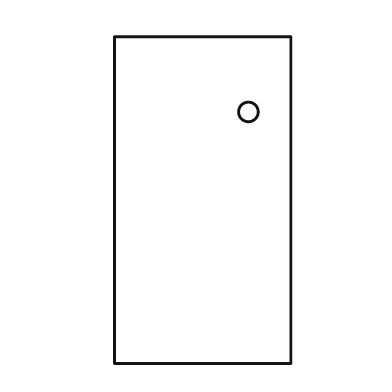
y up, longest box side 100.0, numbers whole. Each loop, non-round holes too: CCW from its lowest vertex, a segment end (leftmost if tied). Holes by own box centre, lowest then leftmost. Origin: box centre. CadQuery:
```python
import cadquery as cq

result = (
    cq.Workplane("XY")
    .moveTo(-27.0, -50.0)
    .lineTo(27.0, -50.0)
    .lineTo(27.0, 50.0)
    .lineTo(-27.0, 50.0)
    .close()
    .moveTo(14.0, 27.0)
    .circle(3.0)
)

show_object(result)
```